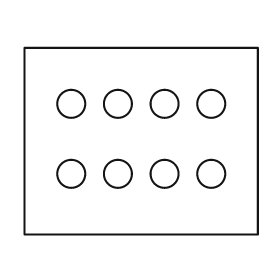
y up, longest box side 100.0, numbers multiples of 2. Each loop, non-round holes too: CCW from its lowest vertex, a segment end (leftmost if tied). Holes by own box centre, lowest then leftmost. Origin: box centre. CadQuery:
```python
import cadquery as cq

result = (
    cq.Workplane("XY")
    .moveTo(-50.0, -40.0)
    .lineTo(50.0, -40.0)
    .lineTo(50.0, 40.0)
    .lineTo(-50.0, 40.0)
    .close()
    .moveTo(-30.0, -14.0)
    .circle(6.0)
    .moveTo(-10.0, -14.0)
    .circle(6.0)
    .moveTo(10.0, -14.0)
    .circle(6.0)
    .moveTo(30.0, -14.0)
    .circle(6.0)
    .moveTo(-30.0, 16.0)
    .circle(6.0)
    .moveTo(-10.0, 16.0)
    .circle(6.0)
    .moveTo(10.0, 16.0)
    .circle(6.0)
    .moveTo(30.0, 16.0)
    .circle(6.0)
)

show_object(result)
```